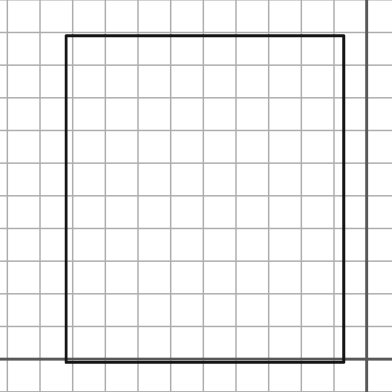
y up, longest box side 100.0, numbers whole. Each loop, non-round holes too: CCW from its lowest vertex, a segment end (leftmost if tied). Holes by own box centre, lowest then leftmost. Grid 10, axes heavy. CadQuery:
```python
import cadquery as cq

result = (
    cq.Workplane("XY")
    .moveTo(-92.0, -1.0)
    .lineTo(-7.0, -1.0)
    .lineTo(-7.0, 99.0)
    .lineTo(-92.0, 99.0)
    .close()
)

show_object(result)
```